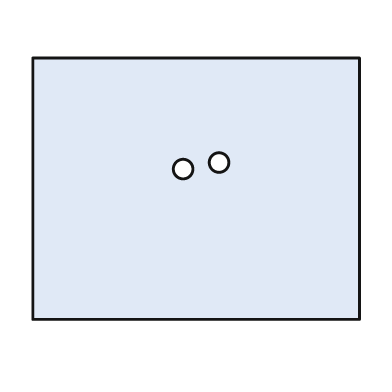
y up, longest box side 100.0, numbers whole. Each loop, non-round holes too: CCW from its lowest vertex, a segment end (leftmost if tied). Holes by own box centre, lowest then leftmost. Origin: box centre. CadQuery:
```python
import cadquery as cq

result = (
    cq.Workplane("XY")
    .moveTo(-50.0, -40.0)
    .lineTo(50.0, -40.0)
    .lineTo(50.0, 40.0)
    .lineTo(-50.0, 40.0)
    .close()
    .moveTo(-4.0, 6.0)
    .circle(3.0)
    .moveTo(7.0, 8.0)
    .circle(3.0)
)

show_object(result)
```